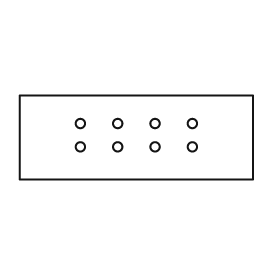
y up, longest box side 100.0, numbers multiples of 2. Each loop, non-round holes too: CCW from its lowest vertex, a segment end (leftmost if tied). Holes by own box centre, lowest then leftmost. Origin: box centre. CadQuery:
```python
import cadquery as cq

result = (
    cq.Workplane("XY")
    .moveTo(-50.0, -18.0)
    .lineTo(50.0, -18.0)
    .lineTo(50.0, 18.0)
    .lineTo(-50.0, 18.0)
    .close()
    .moveTo(-24.0, -4.0)
    .circle(2.0)
    .moveTo(-8.0, -4.0)
    .circle(2.0)
    .moveTo(8.0, -4.0)
    .circle(2.0)
    .moveTo(24.0, -4.0)
    .circle(2.0)
    .moveTo(-24.0, 6.0)
    .circle(2.0)
    .moveTo(-8.0, 6.0)
    .circle(2.0)
    .moveTo(8.0, 6.0)
    .circle(2.0)
    .moveTo(24.0, 6.0)
    .circle(2.0)
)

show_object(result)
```